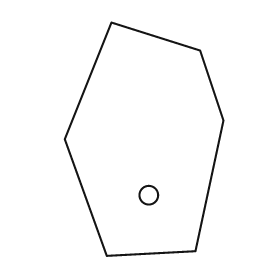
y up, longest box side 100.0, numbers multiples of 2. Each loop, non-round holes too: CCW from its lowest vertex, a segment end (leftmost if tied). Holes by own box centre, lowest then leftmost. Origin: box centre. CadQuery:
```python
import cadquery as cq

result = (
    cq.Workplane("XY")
    .moveTo(-16.0, -50.0)
    .lineTo(22.0, -48.0)
    .lineTo(34.0, 8.0)
    .lineTo(24.0, 38.0)
    .lineTo(-14.0, 50.0)
    .lineTo(-34.0, 0.0)
    .close()
    .moveTo(2.0, -24.0)
    .circle(4.0)
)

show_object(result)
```